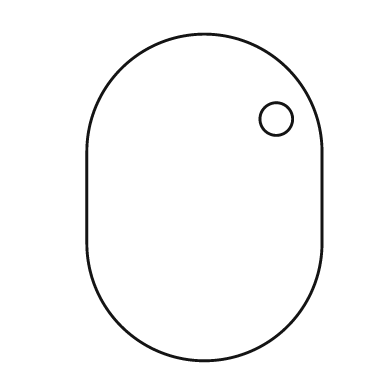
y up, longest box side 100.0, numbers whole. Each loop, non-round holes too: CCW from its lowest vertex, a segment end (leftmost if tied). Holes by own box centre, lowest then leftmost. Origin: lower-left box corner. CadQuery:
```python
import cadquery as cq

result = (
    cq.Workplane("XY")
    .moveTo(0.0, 36.0)
    .threePointArc((36.0, 0.0), (72.0, 36.0))
    .lineTo(72.0, 64.0)
    .threePointArc((36.0, 100.0), (0.0, 64.0))
    .close()
    .moveTo(58.0, 74.0)
    .circle(5.0)
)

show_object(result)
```